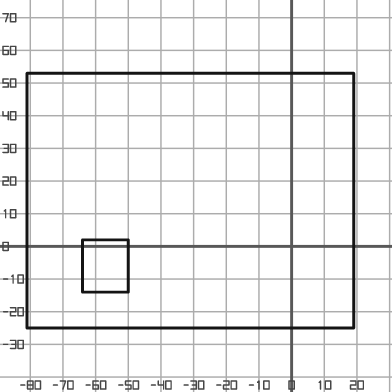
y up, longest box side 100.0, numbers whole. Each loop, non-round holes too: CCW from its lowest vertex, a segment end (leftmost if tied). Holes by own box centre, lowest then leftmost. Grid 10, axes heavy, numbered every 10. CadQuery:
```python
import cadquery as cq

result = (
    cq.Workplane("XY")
    .moveTo(-81.0, -25.0)
    .lineTo(19.0, -25.0)
    .lineTo(19.0, 53.0)
    .lineTo(-81.0, 53.0)
    .close()
    .moveTo(-64.0, -14.0)
    .lineTo(-50.0, -14.0)
    .lineTo(-50.0, 2.0)
    .lineTo(-64.0, 2.0)
    .close()
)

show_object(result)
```